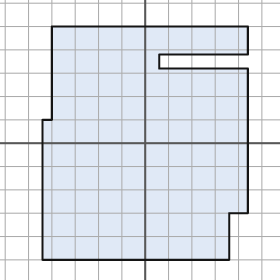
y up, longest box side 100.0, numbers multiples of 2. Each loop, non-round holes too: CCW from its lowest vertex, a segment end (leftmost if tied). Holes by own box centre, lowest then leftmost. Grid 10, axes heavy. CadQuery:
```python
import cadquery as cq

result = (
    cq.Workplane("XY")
    .moveTo(-44.0, -50.0)
    .lineTo(36.0, -50.0)
    .lineTo(36.0, -30.0)
    .lineTo(44.0, -30.0)
    .lineTo(44.0, 32.0)
    .lineTo(6.0, 32.0)
    .lineTo(6.0, 38.0)
    .lineTo(44.0, 38.0)
    .lineTo(44.0, 50.0)
    .lineTo(-40.0, 50.0)
    .lineTo(-40.0, 10.0)
    .lineTo(-44.0, 10.0)
    .close()
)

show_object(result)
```